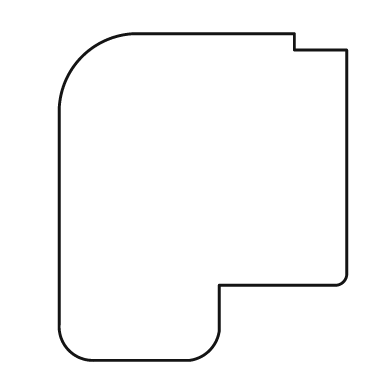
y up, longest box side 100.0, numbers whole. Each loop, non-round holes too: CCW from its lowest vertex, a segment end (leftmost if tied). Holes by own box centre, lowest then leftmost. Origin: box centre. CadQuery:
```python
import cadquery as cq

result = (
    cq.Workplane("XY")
    .moveTo(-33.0, -50.0)
    .lineTo(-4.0, -50.0)
    .threePointArc((2.0, -47.0), (5.0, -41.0))
    .lineTo(5.0, -27.0)
    .lineTo(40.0, -27.0)
    .threePointArc((43.0, -26.0), (44.0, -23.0))
    .lineTo(44.0, 45.0)
    .lineTo(28.0, 45.0)
    .lineTo(28.0, 50.0)
    .lineTo(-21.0, 50.0)
    .threePointArc((-37.0, 43.0), (-44.0, 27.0))
    .lineTo(-44.0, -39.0)
    .threePointArc((-41.0, -47.0), (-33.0, -50.0))
    .close()
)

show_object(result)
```